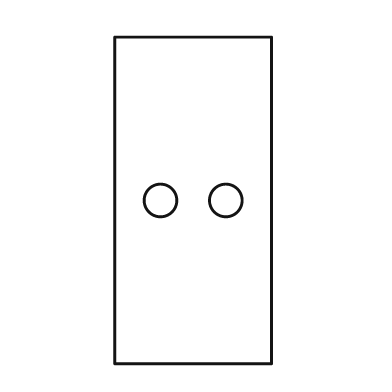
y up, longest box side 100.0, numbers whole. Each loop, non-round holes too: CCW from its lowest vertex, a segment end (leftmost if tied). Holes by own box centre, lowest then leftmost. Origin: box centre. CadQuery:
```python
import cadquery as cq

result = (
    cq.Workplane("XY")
    .moveTo(-24.0, -50.0)
    .lineTo(24.0, -50.0)
    .lineTo(24.0, 50.0)
    .lineTo(-24.0, 50.0)
    .close()
    .moveTo(-10.0, 0.0)
    .circle(5.0)
    .moveTo(10.0, 0.0)
    .circle(5.0)
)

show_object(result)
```